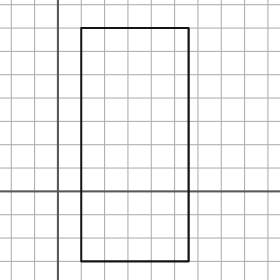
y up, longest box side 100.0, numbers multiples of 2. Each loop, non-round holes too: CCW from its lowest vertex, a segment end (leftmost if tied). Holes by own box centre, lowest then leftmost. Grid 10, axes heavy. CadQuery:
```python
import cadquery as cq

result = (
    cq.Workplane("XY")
    .moveTo(10.0, -30.0)
    .lineTo(56.0, -30.0)
    .lineTo(56.0, 70.0)
    .lineTo(10.0, 70.0)
    .close()
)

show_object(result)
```